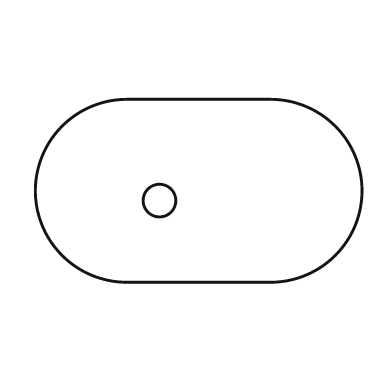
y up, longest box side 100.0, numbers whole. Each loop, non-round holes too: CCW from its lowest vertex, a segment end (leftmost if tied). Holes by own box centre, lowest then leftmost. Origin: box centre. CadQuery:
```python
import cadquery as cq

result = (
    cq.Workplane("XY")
    .moveTo(-22.0, -28.0)
    .lineTo(22.0, -28.0)
    .threePointArc((50.0, 0.0), (22.0, 28.0))
    .lineTo(-22.0, 28.0)
    .threePointArc((-50.0, 0.0), (-22.0, -28.0))
    .close()
    .moveTo(-12.0, -3.0)
    .circle(5.0)
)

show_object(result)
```